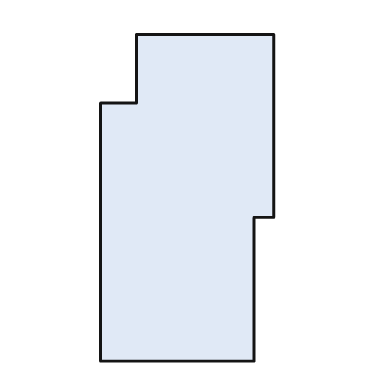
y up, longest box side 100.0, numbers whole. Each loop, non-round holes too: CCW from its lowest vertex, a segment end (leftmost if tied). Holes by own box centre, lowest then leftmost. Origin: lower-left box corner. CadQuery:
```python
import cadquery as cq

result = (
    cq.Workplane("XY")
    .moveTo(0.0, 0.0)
    .lineTo(47.0, 0.0)
    .lineTo(47.0, 44.0)
    .lineTo(53.0, 44.0)
    .lineTo(53.0, 100.0)
    .lineTo(11.0, 100.0)
    .lineTo(11.0, 79.0)
    .lineTo(0.0, 79.0)
    .close()
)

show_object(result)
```